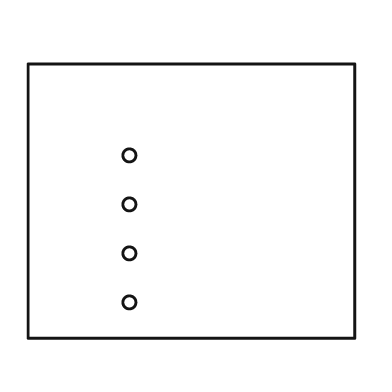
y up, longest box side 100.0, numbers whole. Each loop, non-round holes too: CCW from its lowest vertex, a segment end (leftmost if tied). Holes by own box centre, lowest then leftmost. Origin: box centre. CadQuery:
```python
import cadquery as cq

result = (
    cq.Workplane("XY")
    .moveTo(-50.0, -42.0)
    .lineTo(50.0, -42.0)
    .lineTo(50.0, 42.0)
    .lineTo(-50.0, 42.0)
    .close()
    .moveTo(-19.0, -31.0)
    .circle(2.0)
    .moveTo(-19.0, -16.0)
    .circle(2.0)
    .moveTo(-19.0, -1.0)
    .circle(2.0)
    .moveTo(-19.0, 14.0)
    .circle(2.0)
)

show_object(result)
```